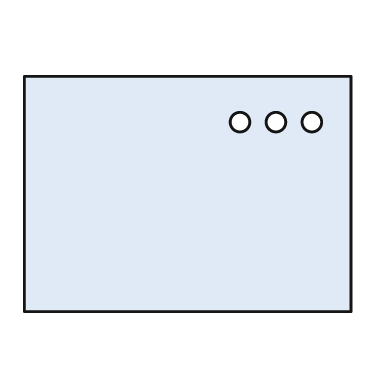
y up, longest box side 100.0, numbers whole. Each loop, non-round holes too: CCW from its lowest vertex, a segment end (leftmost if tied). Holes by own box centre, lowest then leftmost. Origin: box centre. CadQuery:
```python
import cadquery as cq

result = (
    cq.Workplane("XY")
    .moveTo(-50.0, -36.0)
    .lineTo(50.0, -36.0)
    .lineTo(50.0, 36.0)
    .lineTo(-50.0, 36.0)
    .close()
    .moveTo(16.0, 22.0)
    .circle(3.0)
    .moveTo(27.0, 22.0)
    .circle(3.0)
    .moveTo(38.0, 22.0)
    .circle(3.0)
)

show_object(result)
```